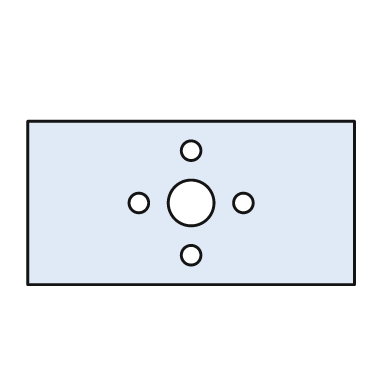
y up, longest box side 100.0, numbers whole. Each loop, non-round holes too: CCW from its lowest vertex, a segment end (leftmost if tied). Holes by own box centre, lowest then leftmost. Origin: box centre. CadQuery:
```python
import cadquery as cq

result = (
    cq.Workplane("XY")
    .moveTo(-50.0, -25.0)
    .lineTo(50.0, -25.0)
    .lineTo(50.0, 25.0)
    .lineTo(-50.0, 25.0)
    .close()
    .moveTo(0.0, -16.0)
    .circle(3.0)
    .moveTo(-16.0, 0.0)
    .circle(3.0)
    .moveTo(0.0, 0.0)
    .circle(7.0)
    .moveTo(16.0, 0.0)
    .circle(3.0)
    .moveTo(0.0, 16.0)
    .circle(3.0)
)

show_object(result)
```